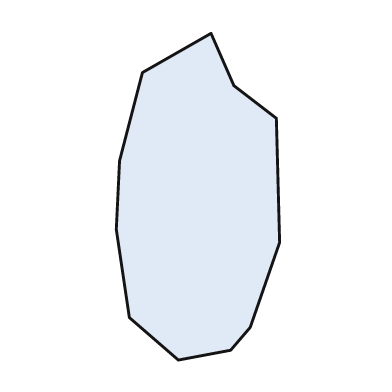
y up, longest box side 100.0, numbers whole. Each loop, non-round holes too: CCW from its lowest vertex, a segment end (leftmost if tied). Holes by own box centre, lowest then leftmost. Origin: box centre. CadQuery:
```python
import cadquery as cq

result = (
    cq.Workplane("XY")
    .moveTo(-6.0, -50.0)
    .lineTo(10.0, -47.0)
    .lineTo(16.0, -40.0)
    .lineTo(25.0, -14.0)
    .lineTo(24.0, 24.0)
    .lineTo(11.0, 34.0)
    .lineTo(4.0, 50.0)
    .lineTo(-17.0, 38.0)
    .lineTo(-24.0, 11.0)
    .lineTo(-25.0, -10.0)
    .lineTo(-21.0, -37.0)
    .close()
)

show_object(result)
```